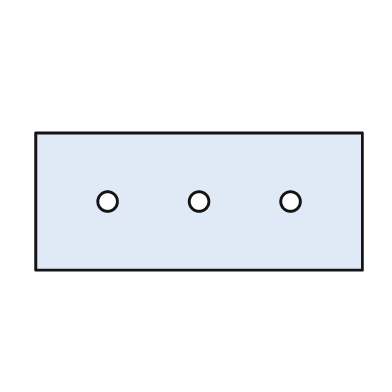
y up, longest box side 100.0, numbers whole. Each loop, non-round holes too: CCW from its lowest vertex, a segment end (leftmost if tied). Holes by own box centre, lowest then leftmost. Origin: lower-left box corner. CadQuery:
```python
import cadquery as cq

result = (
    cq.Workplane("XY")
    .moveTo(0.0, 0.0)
    .lineTo(100.0, 0.0)
    .lineTo(100.0, 42.0)
    .lineTo(0.0, 42.0)
    .close()
    .moveTo(22.0, 21.0)
    .circle(3.0)
    .moveTo(50.0, 21.0)
    .circle(3.0)
    .moveTo(78.0, 21.0)
    .circle(3.0)
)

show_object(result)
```